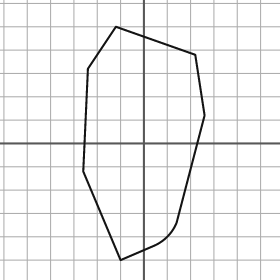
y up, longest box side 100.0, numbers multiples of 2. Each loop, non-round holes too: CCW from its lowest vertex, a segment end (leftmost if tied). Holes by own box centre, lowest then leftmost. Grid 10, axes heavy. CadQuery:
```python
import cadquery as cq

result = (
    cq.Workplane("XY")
    .moveTo(-10.0, -50.0)
    .lineTo(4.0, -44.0)
    .threePointArc((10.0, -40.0), (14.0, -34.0))
    .lineTo(26.0, 12.0)
    .lineTo(22.0, 38.0)
    .lineTo(-12.0, 50.0)
    .lineTo(-24.0, 32.0)
    .lineTo(-26.0, -12.0)
    .close()
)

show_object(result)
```